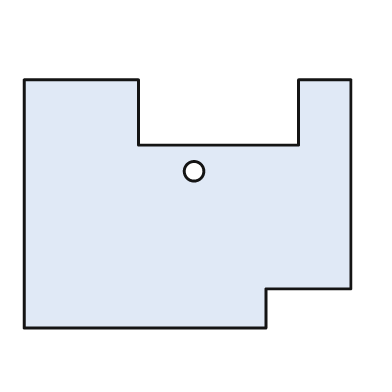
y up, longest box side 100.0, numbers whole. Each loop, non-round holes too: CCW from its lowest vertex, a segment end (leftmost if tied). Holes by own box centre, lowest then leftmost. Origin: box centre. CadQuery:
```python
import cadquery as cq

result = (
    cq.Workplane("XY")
    .moveTo(-50.0, -38.0)
    .lineTo(24.0, -38.0)
    .lineTo(24.0, -26.0)
    .lineTo(50.0, -26.0)
    .lineTo(50.0, 38.0)
    .lineTo(34.0, 38.0)
    .lineTo(34.0, 18.0)
    .lineTo(-15.0, 18.0)
    .lineTo(-15.0, 38.0)
    .lineTo(-50.0, 38.0)
    .close()
    .moveTo(2.0, 10.0)
    .circle(3.0)
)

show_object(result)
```